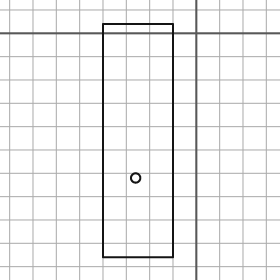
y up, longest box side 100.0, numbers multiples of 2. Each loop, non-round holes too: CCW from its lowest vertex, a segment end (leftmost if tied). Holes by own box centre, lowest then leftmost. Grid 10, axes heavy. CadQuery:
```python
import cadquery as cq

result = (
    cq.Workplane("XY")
    .moveTo(-40.0, -96.0)
    .lineTo(-10.0, -96.0)
    .lineTo(-10.0, 4.0)
    .lineTo(-40.0, 4.0)
    .close()
    .moveTo(-26.0, -62.0)
    .circle(2.0)
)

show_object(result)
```